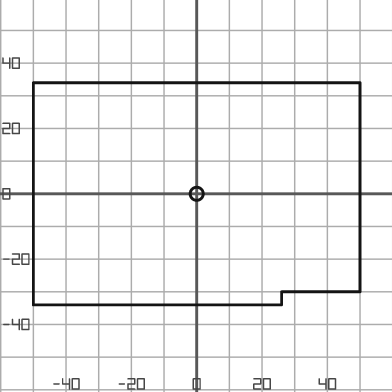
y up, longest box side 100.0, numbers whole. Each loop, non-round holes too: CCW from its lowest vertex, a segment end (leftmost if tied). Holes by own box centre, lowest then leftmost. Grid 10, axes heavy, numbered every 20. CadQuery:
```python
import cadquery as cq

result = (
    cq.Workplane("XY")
    .moveTo(-50.0, -34.0)
    .lineTo(26.0, -34.0)
    .lineTo(26.0, -30.0)
    .lineTo(50.0, -30.0)
    .lineTo(50.0, 34.0)
    .lineTo(-50.0, 34.0)
    .close()
    .moveTo(0.0, 0.0)
    .circle(2.0)
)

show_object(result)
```